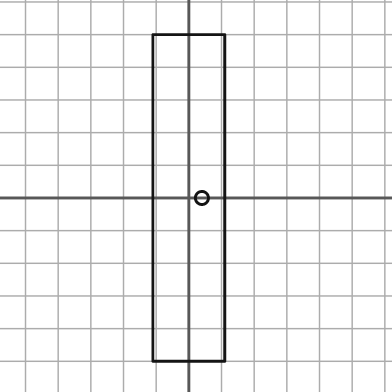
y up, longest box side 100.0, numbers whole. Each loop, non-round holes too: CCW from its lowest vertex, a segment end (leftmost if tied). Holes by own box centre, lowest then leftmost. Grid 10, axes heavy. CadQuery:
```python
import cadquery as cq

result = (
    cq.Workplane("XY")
    .moveTo(-11.0, -50.0)
    .lineTo(11.0, -50.0)
    .lineTo(11.0, 50.0)
    .lineTo(-11.0, 50.0)
    .close()
    .moveTo(4.0, 0.0)
    .circle(2.0)
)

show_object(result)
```